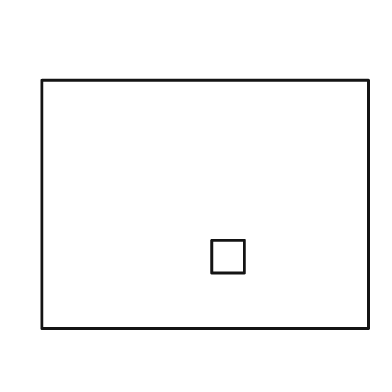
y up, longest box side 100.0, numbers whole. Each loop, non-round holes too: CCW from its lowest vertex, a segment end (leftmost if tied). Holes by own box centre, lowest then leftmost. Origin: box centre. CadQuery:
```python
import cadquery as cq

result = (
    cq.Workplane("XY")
    .moveTo(-50.0, -38.0)
    .lineTo(50.0, -38.0)
    .lineTo(50.0, 38.0)
    .lineTo(-50.0, 38.0)
    .close()
    .moveTo(2.0, -21.0)
    .lineTo(12.0, -21.0)
    .lineTo(12.0, -11.0)
    .lineTo(2.0, -11.0)
    .close()
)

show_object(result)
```